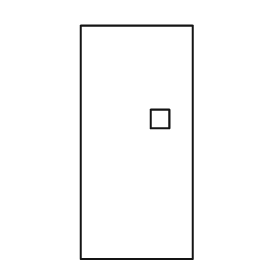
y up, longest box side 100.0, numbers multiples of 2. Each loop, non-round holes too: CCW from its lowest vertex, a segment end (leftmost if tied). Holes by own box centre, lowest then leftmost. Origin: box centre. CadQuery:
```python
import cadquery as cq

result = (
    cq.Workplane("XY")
    .moveTo(-24.0, -50.0)
    .lineTo(24.0, -50.0)
    .lineTo(24.0, 50.0)
    .lineTo(-24.0, 50.0)
    .close()
    .moveTo(6.0, 6.0)
    .lineTo(14.0, 6.0)
    .lineTo(14.0, 14.0)
    .lineTo(6.0, 14.0)
    .close()
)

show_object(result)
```